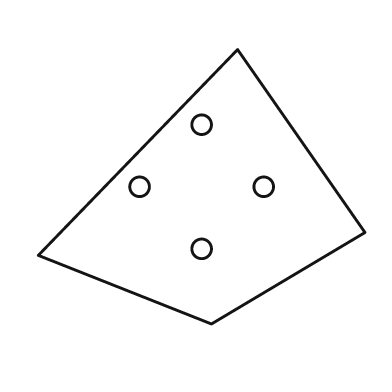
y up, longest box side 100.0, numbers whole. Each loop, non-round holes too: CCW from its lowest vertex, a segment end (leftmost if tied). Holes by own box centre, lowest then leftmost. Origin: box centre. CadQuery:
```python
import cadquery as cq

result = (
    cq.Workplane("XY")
    .moveTo(3.0, -42.0)
    .lineTo(50.0, -14.0)
    .lineTo(11.0, 42.0)
    .lineTo(-50.0, -21.0)
    .close()
    .moveTo(0.0, -19.0)
    .circle(3.0)
    .moveTo(-19.0, 0.0)
    .circle(3.0)
    .moveTo(19.0, 0.0)
    .circle(3.0)
    .moveTo(0.0, 19.0)
    .circle(3.0)
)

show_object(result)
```